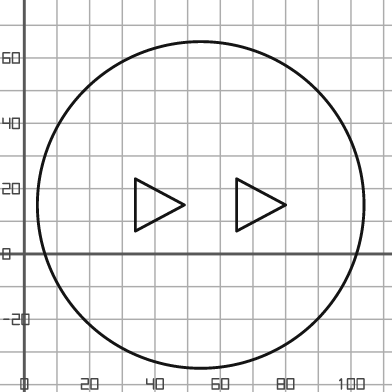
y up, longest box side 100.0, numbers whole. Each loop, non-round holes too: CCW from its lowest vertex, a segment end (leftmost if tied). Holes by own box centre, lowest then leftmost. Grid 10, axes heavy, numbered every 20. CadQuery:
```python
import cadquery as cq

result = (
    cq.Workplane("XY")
    .moveTo(54.0, 15.0)
    .circle(50.0)
    .moveTo(34.0, 7.0)
    .lineTo(49.0, 15.0)
    .lineTo(34.0, 23.0)
    .close()
    .moveTo(65.0, 7.0)
    .lineTo(80.0, 15.0)
    .lineTo(65.0, 23.0)
    .close()
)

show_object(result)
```